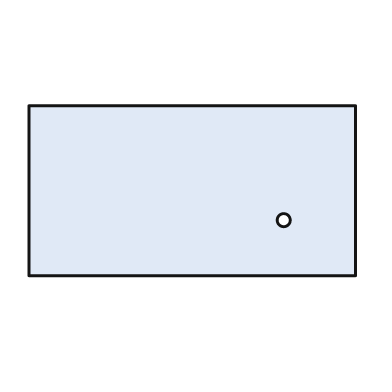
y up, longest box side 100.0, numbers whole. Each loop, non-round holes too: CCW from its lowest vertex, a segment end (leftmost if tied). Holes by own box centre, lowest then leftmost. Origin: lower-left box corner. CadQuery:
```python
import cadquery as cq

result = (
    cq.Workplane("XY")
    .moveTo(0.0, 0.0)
    .lineTo(100.0, 0.0)
    .lineTo(100.0, 52.0)
    .lineTo(0.0, 52.0)
    .close()
    .moveTo(78.0, 17.0)
    .circle(2.0)
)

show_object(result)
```